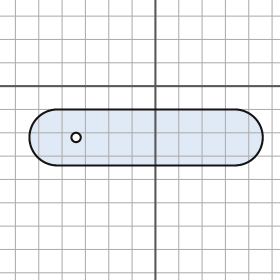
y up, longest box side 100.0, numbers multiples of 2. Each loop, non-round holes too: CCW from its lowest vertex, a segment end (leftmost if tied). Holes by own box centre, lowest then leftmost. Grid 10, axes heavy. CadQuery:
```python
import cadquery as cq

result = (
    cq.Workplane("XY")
    .moveTo(-42.0, -34.0)
    .lineTo(34.0, -34.0)
    .threePointArc((46.0, -22.0), (34.0, -10.0))
    .lineTo(-42.0, -10.0)
    .threePointArc((-54.0, -22.0), (-42.0, -34.0))
    .close()
    .moveTo(-34.0, -22.0)
    .circle(2.0)
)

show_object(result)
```